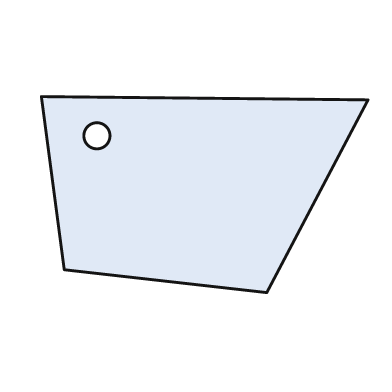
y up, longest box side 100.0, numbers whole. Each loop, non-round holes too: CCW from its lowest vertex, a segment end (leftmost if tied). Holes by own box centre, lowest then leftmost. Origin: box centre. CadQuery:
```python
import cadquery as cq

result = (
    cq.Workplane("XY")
    .moveTo(19.0, -30.0)
    .lineTo(50.0, 29.0)
    .lineTo(-50.0, 30.0)
    .lineTo(-43.0, -23.0)
    .close()
    .moveTo(-33.0, 18.0)
    .circle(4.0)
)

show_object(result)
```